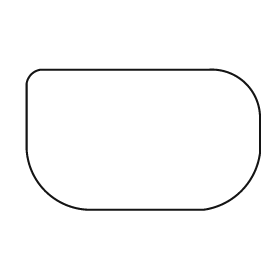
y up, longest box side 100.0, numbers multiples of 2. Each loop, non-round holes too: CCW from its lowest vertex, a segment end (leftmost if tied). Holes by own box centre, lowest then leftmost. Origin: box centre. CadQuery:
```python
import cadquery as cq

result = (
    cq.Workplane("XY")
    .moveTo(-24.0, -30.0)
    .lineTo(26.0, -30.0)
    .threePointArc((42.0, -22.0), (50.0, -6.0))
    .lineTo(50.0, 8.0)
    .threePointArc((44.0, 24.0), (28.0, 30.0))
    .lineTo(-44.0, 30.0)
    .threePointArc((-48.0, 28.0), (-50.0, 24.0))
    .lineTo(-50.0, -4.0)
    .threePointArc((-42.0, -22.0), (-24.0, -30.0))
    .close()
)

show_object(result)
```